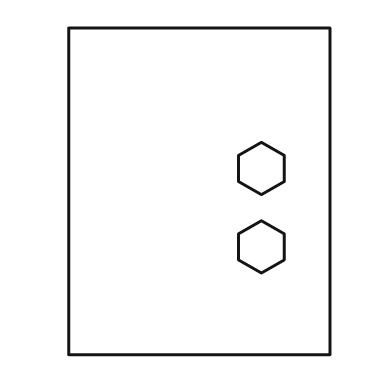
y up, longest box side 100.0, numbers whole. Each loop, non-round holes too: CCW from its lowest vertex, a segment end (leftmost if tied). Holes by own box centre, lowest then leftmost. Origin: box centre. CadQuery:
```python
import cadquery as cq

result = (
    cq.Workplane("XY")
    .moveTo(-40.0, -50.0)
    .lineTo(40.0, -50.0)
    .lineTo(40.0, 50.0)
    .lineTo(-40.0, 50.0)
    .close()
    .moveTo(19.0, -25.0)
    .lineTo(26.0, -21.0)
    .lineTo(26.0, -13.0)
    .lineTo(19.0, -9.0)
    .lineTo(12.0, -13.0)
    .lineTo(12.0, -21.0)
    .close()
    .moveTo(19.0, -1.0)
    .lineTo(26.0, 3.0)
    .lineTo(26.0, 11.0)
    .lineTo(19.0, 15.0)
    .lineTo(12.0, 11.0)
    .lineTo(12.0, 3.0)
    .close()
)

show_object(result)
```